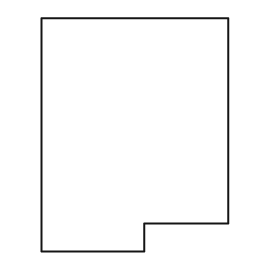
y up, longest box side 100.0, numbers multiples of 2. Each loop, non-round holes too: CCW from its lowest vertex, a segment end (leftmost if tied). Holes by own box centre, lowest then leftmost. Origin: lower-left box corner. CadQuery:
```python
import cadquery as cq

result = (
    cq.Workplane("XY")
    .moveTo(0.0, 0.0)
    .lineTo(44.0, 0.0)
    .lineTo(44.0, 12.0)
    .lineTo(80.0, 12.0)
    .lineTo(80.0, 100.0)
    .lineTo(0.0, 100.0)
    .close()
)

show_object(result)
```